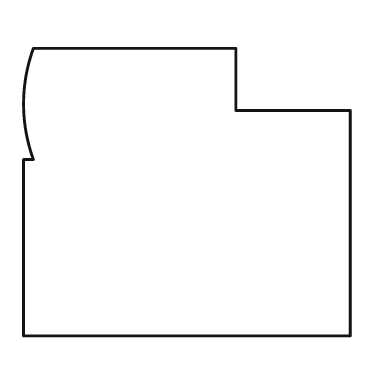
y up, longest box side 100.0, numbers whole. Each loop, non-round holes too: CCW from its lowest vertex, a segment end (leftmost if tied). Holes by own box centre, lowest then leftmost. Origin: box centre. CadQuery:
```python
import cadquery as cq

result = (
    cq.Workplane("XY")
    .moveTo(-50.0, -44.0)
    .lineTo(50.0, -44.0)
    .lineTo(50.0, 25.0)
    .lineTo(15.0, 25.0)
    .lineTo(15.0, 44.0)
    .lineTo(-47.0, 44.0)
    .threePointArc((-50.0, 27.0), (-47.0, 10.0))
    .lineTo(-50.0, 10.0)
    .close()
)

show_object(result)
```